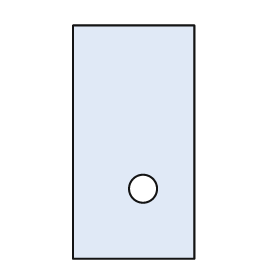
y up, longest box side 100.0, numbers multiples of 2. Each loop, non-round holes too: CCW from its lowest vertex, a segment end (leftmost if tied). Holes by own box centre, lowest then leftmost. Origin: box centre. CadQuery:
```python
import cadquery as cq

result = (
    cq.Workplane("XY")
    .moveTo(-26.0, -50.0)
    .lineTo(26.0, -50.0)
    .lineTo(26.0, 50.0)
    .lineTo(-26.0, 50.0)
    .close()
    .moveTo(4.0, -20.0)
    .circle(6.0)
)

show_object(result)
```